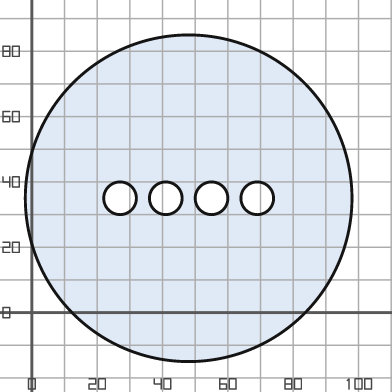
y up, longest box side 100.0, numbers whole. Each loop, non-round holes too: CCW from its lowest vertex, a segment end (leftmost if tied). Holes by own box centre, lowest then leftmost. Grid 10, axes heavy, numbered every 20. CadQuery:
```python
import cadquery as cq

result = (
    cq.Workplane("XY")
    .moveTo(48.0, 35.0)
    .circle(50.0)
    .moveTo(27.0, 35.0)
    .circle(5.0)
    .moveTo(41.0, 35.0)
    .circle(5.0)
    .moveTo(55.0, 35.0)
    .circle(5.0)
    .moveTo(69.0, 35.0)
    .circle(5.0)
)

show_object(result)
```